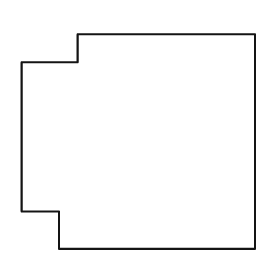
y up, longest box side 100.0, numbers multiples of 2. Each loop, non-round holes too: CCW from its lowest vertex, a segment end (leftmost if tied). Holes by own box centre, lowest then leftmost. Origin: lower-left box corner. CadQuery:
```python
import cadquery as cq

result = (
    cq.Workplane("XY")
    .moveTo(16.0, 0.0)
    .lineTo(100.0, 0.0)
    .lineTo(100.0, 92.0)
    .lineTo(24.0, 92.0)
    .lineTo(24.0, 80.0)
    .lineTo(0.0, 80.0)
    .lineTo(0.0, 16.0)
    .lineTo(16.0, 16.0)
    .close()
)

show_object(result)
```